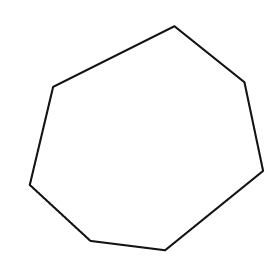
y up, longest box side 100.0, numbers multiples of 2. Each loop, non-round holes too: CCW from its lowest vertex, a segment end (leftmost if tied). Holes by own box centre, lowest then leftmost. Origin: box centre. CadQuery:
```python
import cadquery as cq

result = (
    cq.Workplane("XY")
    .moveTo(8.0, -48.0)
    .lineTo(50.0, -14.0)
    .lineTo(42.0, 24.0)
    .lineTo(12.0, 48.0)
    .lineTo(-40.0, 22.0)
    .lineTo(-50.0, -20.0)
    .lineTo(-24.0, -44.0)
    .close()
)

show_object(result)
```